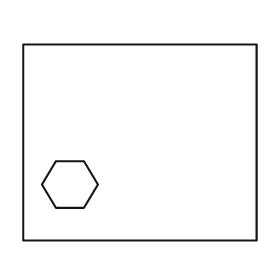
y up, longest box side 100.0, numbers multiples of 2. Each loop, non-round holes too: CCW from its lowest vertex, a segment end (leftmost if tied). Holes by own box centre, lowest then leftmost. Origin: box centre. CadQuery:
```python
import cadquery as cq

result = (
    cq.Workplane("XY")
    .moveTo(-50.0, -42.0)
    .lineTo(50.0, -42.0)
    .lineTo(50.0, 42.0)
    .lineTo(-50.0, 42.0)
    .close()
    .moveTo(-36.0, -28.0)
    .lineTo(-24.0, -28.0)
    .lineTo(-18.0, -18.0)
    .lineTo(-24.0, -8.0)
    .lineTo(-36.0, -8.0)
    .lineTo(-42.0, -18.0)
    .close()
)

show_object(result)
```